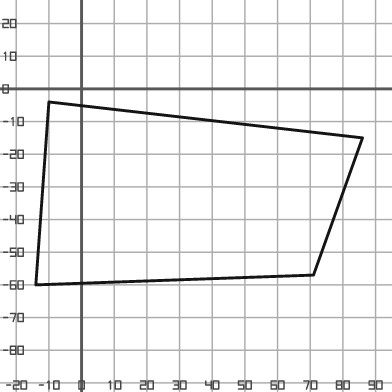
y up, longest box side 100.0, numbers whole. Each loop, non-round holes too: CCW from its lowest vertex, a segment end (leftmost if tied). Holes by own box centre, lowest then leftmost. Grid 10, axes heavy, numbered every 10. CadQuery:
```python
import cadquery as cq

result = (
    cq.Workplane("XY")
    .moveTo(-14.0, -60.0)
    .lineTo(71.0, -57.0)
    .lineTo(86.0, -15.0)
    .lineTo(-10.0, -4.0)
    .close()
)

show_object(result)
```